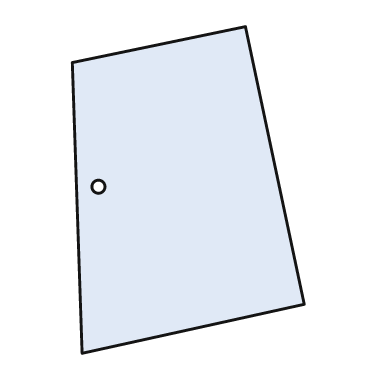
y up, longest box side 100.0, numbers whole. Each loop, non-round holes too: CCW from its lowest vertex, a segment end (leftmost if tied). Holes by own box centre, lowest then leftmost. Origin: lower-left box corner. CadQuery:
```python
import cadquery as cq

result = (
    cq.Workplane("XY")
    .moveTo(3.0, 0.0)
    .lineTo(71.0, 15.0)
    .lineTo(53.0, 100.0)
    .lineTo(0.0, 89.0)
    .close()
    .moveTo(8.0, 51.0)
    .circle(2.0)
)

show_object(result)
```